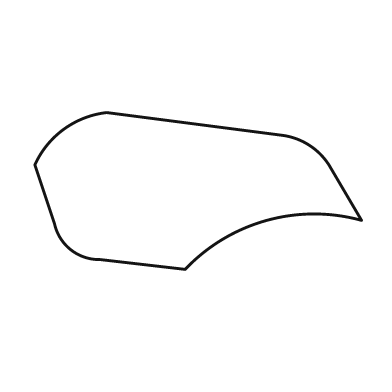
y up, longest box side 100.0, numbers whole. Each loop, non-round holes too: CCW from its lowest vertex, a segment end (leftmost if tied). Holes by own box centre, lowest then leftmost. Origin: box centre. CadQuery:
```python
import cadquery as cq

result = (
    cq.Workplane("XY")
    .moveTo(-4.0, -24.0)
    .threePointArc((21.0, -9.0), (50.0, -9.0))
    .lineTo(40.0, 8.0)
    .threePointArc((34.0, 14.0), (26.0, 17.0))
    .lineTo(-28.0, 24.0)
    .threePointArc((-41.0, 19.0), (-50.0, 8.0))
    .lineTo(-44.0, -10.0)
    .threePointArc((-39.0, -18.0), (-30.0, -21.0))
    .close()
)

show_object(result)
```